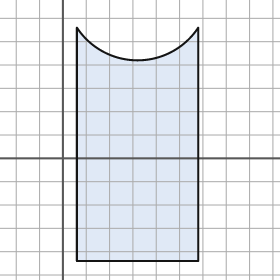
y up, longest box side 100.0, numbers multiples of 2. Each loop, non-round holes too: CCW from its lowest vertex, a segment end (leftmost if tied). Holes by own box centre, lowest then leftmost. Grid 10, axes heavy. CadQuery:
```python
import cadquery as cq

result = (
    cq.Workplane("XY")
    .moveTo(6.0, -44.0)
    .lineTo(58.0, -44.0)
    .lineTo(58.0, 56.0)
    .threePointArc((32.0, 42.0), (6.0, 56.0))
    .close()
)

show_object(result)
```